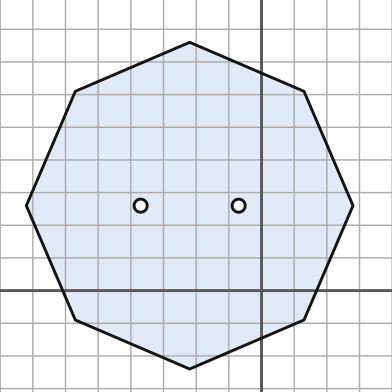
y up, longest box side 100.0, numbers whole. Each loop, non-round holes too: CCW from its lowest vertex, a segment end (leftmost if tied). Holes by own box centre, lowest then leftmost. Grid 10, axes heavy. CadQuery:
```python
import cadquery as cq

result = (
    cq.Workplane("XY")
    .moveTo(-22.0, -24.0)
    .lineTo(13.0, -9.0)
    .lineTo(28.0, 26.0)
    .lineTo(13.0, 61.0)
    .lineTo(-22.0, 76.0)
    .lineTo(-57.0, 61.0)
    .lineTo(-72.0, 26.0)
    .lineTo(-57.0, -9.0)
    .close()
    .moveTo(-37.0, 26.0)
    .circle(2.0)
    .moveTo(-7.0, 26.0)
    .circle(2.0)
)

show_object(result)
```